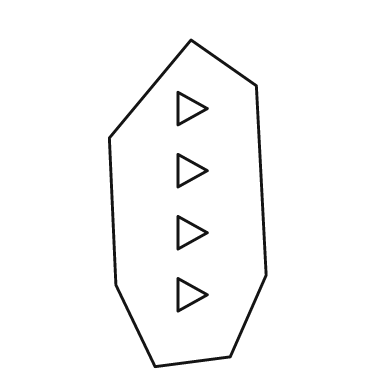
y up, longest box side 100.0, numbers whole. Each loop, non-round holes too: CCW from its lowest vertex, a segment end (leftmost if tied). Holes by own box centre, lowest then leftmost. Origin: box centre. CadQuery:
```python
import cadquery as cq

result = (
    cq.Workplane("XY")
    .moveTo(-10.0, -50.0)
    .lineTo(13.0, -47.0)
    .lineTo(24.0, -22.0)
    .lineTo(21.0, 36.0)
    .lineTo(1.0, 50.0)
    .lineTo(-24.0, 20.0)
    .lineTo(-22.0, -25.0)
    .close()
    .moveTo(-3.0, -33.0)
    .lineTo(6.0, -28.0)
    .lineTo(-3.0, -23.0)
    .close()
    .moveTo(-3.0, -14.0)
    .lineTo(6.0, -9.0)
    .lineTo(-3.0, -4.0)
    .close()
    .moveTo(-3.0, 5.0)
    .lineTo(6.0, 10.0)
    .lineTo(-3.0, 15.0)
    .close()
    .moveTo(-3.0, 24.0)
    .lineTo(6.0, 29.0)
    .lineTo(-3.0, 34.0)
    .close()
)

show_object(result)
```